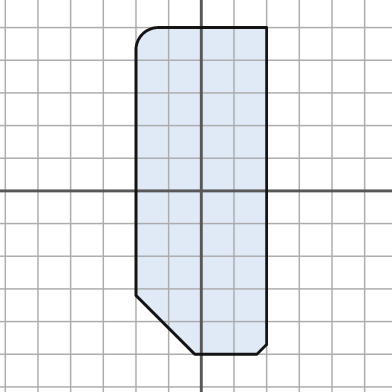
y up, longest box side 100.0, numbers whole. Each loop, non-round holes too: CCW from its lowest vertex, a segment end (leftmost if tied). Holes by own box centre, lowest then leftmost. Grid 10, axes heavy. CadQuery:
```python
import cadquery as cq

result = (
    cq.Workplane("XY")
    .moveTo(-2.0, -50.0)
    .lineTo(17.0, -50.0)
    .lineTo(20.0, -47.0)
    .lineTo(20.0, 50.0)
    .lineTo(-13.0, 50.0)
    .threePointArc((-18.0, 48.0), (-20.0, 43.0))
    .lineTo(-20.0, -32.0)
    .close()
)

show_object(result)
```